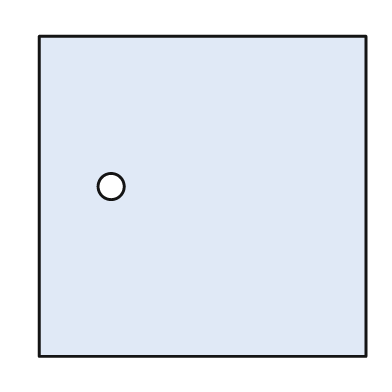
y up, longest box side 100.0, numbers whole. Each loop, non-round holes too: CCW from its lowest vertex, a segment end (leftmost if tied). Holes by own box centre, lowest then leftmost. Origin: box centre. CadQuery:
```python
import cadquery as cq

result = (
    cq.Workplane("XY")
    .moveTo(-50.0, -49.0)
    .lineTo(50.0, -49.0)
    .lineTo(50.0, 49.0)
    .lineTo(-50.0, 49.0)
    .close()
    .moveTo(-28.0, 3.0)
    .circle(4.0)
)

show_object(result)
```